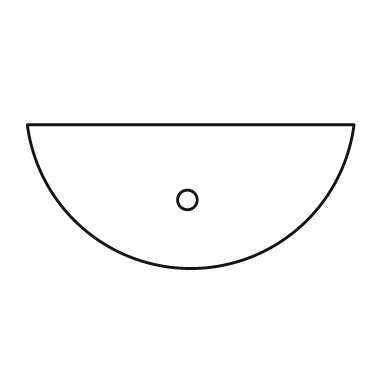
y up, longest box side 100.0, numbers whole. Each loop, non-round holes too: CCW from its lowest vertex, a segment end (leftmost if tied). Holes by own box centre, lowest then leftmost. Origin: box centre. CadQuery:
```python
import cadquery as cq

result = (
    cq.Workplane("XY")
    .moveTo(-50.0, 22.0)
    .threePointArc((0.0, -22.0), (50.0, 22.0))
    .close()
    .moveTo(-1.0, -1.0)
    .circle(3.0)
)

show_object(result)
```